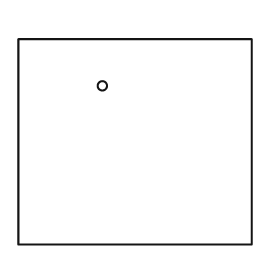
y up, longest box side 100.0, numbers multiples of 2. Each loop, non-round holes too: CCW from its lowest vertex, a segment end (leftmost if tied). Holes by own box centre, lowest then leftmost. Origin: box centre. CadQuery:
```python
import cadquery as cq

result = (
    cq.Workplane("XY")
    .moveTo(-50.0, -44.0)
    .lineTo(50.0, -44.0)
    .lineTo(50.0, 44.0)
    .lineTo(-50.0, 44.0)
    .close()
    .moveTo(-14.0, 24.0)
    .circle(2.0)
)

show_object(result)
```